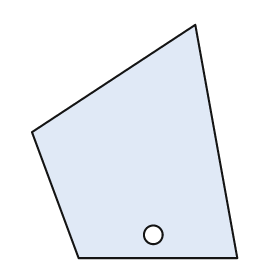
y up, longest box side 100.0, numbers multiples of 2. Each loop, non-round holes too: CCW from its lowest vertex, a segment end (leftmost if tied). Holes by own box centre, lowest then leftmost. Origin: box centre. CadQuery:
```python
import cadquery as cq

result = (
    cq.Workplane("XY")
    .moveTo(-24.0, -50.0)
    .lineTo(44.0, -50.0)
    .lineTo(26.0, 50.0)
    .lineTo(-44.0, 4.0)
    .close()
    .moveTo(8.0, -40.0)
    .circle(4.0)
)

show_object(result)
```